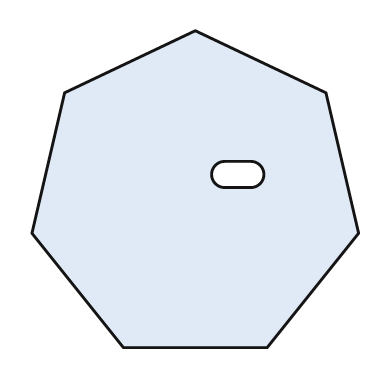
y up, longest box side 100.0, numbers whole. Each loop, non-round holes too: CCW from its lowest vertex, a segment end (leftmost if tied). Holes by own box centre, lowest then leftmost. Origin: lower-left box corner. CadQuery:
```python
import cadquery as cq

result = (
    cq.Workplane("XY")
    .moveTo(28.0, 0.0)
    .lineTo(72.0, 0.0)
    .lineTo(100.0, 35.0)
    .lineTo(90.0, 78.0)
    .lineTo(50.0, 97.0)
    .lineTo(10.0, 78.0)
    .lineTo(0.0, 35.0)
    .close()
    .moveTo(59.0, 49.0)
    .lineTo(67.0, 49.0)
    .threePointArc((71.0, 53.0), (67.0, 57.0))
    .lineTo(59.0, 57.0)
    .threePointArc((55.0, 53.0), (59.0, 49.0))
    .close()
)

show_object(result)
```